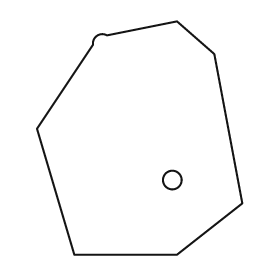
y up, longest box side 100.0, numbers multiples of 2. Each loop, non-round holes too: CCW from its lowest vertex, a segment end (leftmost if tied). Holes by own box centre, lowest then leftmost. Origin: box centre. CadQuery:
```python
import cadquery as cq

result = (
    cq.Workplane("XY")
    .moveTo(-28.0, -50.0)
    .lineTo(16.0, -50.0)
    .lineTo(44.0, -28.0)
    .lineTo(32.0, 36.0)
    .lineTo(16.0, 50.0)
    .lineTo(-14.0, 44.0)
    .threePointArc((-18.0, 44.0), (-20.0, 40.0))
    .lineTo(-44.0, 4.0)
    .close()
    .moveTo(14.0, -18.0)
    .circle(4.0)
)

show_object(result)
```